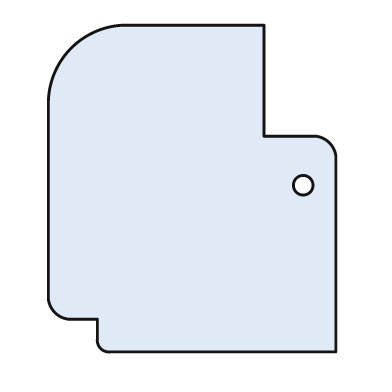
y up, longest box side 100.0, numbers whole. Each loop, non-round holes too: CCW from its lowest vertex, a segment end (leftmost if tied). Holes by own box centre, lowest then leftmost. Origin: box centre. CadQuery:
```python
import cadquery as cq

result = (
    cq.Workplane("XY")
    .moveTo(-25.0, -50.0)
    .lineTo(44.0, -50.0)
    .lineTo(44.0, 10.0)
    .threePointArc((42.0, 14.0), (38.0, 16.0))
    .lineTo(22.0, 16.0)
    .lineTo(22.0, 50.0)
    .lineTo(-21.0, 50.0)
    .threePointArc((-37.0, 43.0), (-44.0, 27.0))
    .lineTo(-44.0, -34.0)
    .threePointArc((-42.0, -38.0), (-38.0, -40.0))
    .lineTo(-29.0, -40.0)
    .lineTo(-29.0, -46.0)
    .threePointArc((-28.0, -49.0), (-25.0, -50.0))
    .close()
    .moveTo(34.0, 1.0)
    .circle(3.0)
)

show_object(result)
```